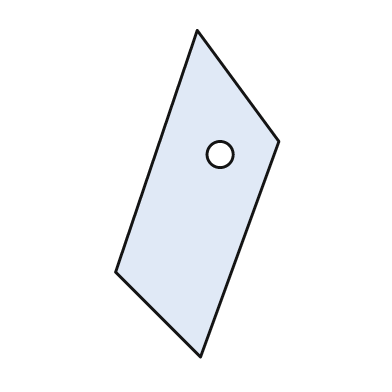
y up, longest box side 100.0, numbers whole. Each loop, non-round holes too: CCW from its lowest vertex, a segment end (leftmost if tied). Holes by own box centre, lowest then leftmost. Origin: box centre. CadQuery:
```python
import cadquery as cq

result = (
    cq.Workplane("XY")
    .moveTo(1.0, -50.0)
    .lineTo(25.0, 16.0)
    .lineTo(0.0, 50.0)
    .lineTo(-25.0, -24.0)
    .close()
    .moveTo(7.0, 12.0)
    .circle(4.0)
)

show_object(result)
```